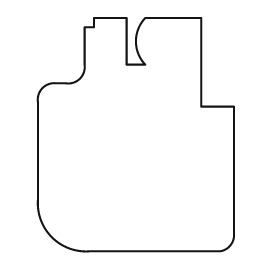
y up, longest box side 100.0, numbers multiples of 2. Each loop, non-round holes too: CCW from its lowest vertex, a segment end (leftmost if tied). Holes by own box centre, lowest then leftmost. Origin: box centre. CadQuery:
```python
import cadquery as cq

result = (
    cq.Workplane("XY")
    .moveTo(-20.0, -50.0)
    .lineTo(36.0, -50.0)
    .threePointArc((40.0, -48.0), (42.0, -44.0))
    .lineTo(42.0, 12.0)
    .lineTo(28.0, 12.0)
    .lineTo(28.0, 50.0)
    .lineTo(4.0, 50.0)
    .threePointArc((0.0, 40.0), (4.0, 30.0))
    .lineTo(-4.0, 30.0)
    .lineTo(-4.0, 50.0)
    .lineTo(-18.0, 50.0)
    .lineTo(-18.0, 46.0)
    .lineTo(-22.0, 46.0)
    .lineTo(-22.0, 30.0)
    .threePointArc((-24.0, 24.0), (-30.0, 22.0))
    .lineTo(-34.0, 22.0)
    .threePointArc((-40.0, 20.0), (-42.0, 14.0))
    .lineTo(-42.0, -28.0)
    .threePointArc((-36.0, -44.0), (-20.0, -50.0))
    .close()
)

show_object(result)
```